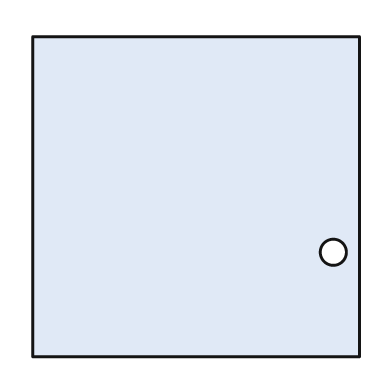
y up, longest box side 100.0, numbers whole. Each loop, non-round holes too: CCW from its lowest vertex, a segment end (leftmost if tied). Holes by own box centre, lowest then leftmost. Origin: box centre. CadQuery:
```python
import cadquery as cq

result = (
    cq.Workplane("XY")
    .moveTo(-50.0, -49.0)
    .lineTo(50.0, -49.0)
    .lineTo(50.0, 49.0)
    .lineTo(-50.0, 49.0)
    .close()
    .moveTo(42.0, -17.0)
    .circle(4.0)
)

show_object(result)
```